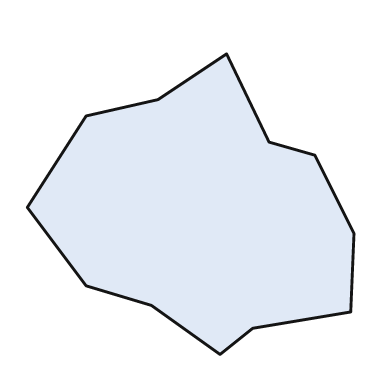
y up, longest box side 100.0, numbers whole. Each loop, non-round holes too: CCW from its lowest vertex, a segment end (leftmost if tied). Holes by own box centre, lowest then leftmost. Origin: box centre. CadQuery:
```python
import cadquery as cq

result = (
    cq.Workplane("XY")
    .moveTo(9.0, -46.0)
    .lineTo(19.0, -38.0)
    .lineTo(49.0, -33.0)
    .lineTo(50.0, -9.0)
    .lineTo(38.0, 15.0)
    .lineTo(24.0, 19.0)
    .lineTo(11.0, 46.0)
    .lineTo(-10.0, 32.0)
    .lineTo(-32.0, 27.0)
    .lineTo(-50.0, -1.0)
    .lineTo(-32.0, -25.0)
    .lineTo(-12.0, -31.0)
    .close()
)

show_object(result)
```